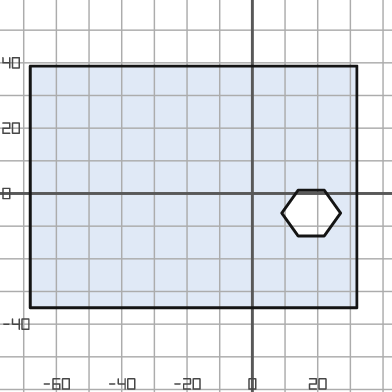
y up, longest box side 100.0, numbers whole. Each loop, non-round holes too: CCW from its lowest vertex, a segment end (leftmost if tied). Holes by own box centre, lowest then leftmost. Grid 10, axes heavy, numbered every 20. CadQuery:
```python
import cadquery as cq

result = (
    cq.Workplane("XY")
    .moveTo(-68.0, -35.0)
    .lineTo(32.0, -35.0)
    .lineTo(32.0, 39.0)
    .lineTo(-68.0, 39.0)
    .close()
    .moveTo(14.0, -13.0)
    .lineTo(22.0, -13.0)
    .lineTo(27.0, -6.0)
    .lineTo(22.0, 1.0)
    .lineTo(14.0, 1.0)
    .lineTo(9.0, -6.0)
    .close()
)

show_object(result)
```